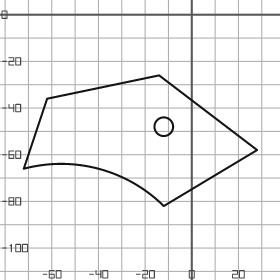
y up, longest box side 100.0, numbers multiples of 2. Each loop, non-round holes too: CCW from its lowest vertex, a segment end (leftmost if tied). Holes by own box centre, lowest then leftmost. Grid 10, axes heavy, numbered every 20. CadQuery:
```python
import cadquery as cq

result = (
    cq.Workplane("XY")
    .moveTo(-12.0, -82.0)
    .lineTo(28.0, -58.0)
    .lineTo(-14.0, -26.0)
    .lineTo(-62.0, -36.0)
    .lineTo(-72.0, -66.0)
    .threePointArc((-40.0, -66.0), (-12.0, -82.0))
    .close()
    .moveTo(-12.0, -48.0)
    .circle(4.0)
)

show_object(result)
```